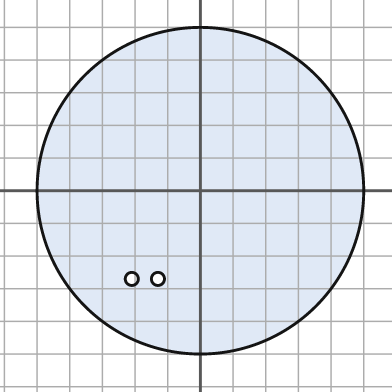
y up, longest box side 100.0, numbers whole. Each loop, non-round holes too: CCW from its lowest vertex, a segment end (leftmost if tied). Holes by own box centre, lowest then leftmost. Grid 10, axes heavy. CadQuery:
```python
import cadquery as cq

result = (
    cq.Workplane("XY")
    .moveTo(0.0, 0.0)
    .circle(50.0)
    .moveTo(-21.0, -27.0)
    .circle(2.0)
    .moveTo(-13.0, -27.0)
    .circle(2.0)
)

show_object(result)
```